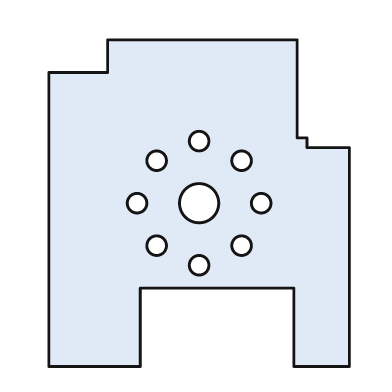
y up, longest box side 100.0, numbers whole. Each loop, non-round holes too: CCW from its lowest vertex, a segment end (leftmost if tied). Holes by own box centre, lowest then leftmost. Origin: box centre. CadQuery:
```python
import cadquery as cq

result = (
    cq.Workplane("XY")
    .moveTo(-46.0, -50.0)
    .lineTo(-18.0, -50.0)
    .lineTo(-18.0, -26.0)
    .lineTo(29.0, -26.0)
    .lineTo(29.0, -50.0)
    .lineTo(46.0, -50.0)
    .lineTo(46.0, 17.0)
    .lineTo(33.0, 17.0)
    .lineTo(33.0, 20.0)
    .lineTo(30.0, 20.0)
    .lineTo(30.0, 50.0)
    .lineTo(-28.0, 50.0)
    .lineTo(-28.0, 40.0)
    .lineTo(-46.0, 40.0)
    .close()
    .moveTo(0.0, -19.0)
    .circle(3.0)
    .moveTo(-13.0, -13.0)
    .circle(3.0)
    .moveTo(13.0, -13.0)
    .circle(3.0)
    .moveTo(-19.0, 0.0)
    .circle(3.0)
    .moveTo(0.0, 0.0)
    .circle(6.0)
    .moveTo(19.0, 0.0)
    .circle(3.0)
    .moveTo(-13.0, 13.0)
    .circle(3.0)
    .moveTo(13.0, 13.0)
    .circle(3.0)
    .moveTo(0.0, 19.0)
    .circle(3.0)
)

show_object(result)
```